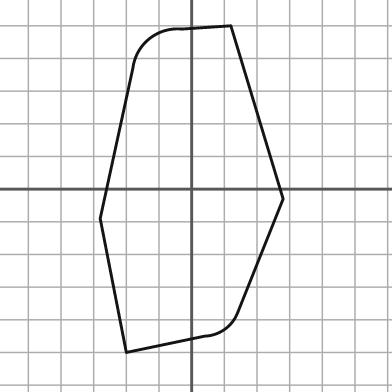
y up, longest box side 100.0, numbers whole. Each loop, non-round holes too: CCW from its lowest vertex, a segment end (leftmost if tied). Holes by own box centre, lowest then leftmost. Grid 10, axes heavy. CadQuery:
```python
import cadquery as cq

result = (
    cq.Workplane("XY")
    .moveTo(-20.0, -50.0)
    .lineTo(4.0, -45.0)
    .threePointArc((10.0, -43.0), (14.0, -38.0))
    .lineTo(28.0, -3.0)
    .lineTo(12.0, 50.0)
    .lineTo(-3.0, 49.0)
    .threePointArc((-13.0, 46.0), (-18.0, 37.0))
    .lineTo(-28.0, -9.0)
    .close()
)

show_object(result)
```